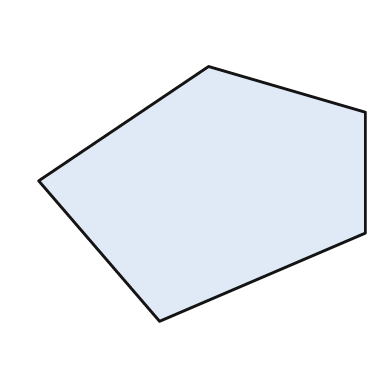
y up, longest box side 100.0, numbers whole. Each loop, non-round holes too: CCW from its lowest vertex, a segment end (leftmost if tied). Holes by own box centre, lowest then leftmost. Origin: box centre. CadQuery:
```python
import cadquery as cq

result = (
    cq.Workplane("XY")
    .moveTo(-13.0, -39.0)
    .lineTo(50.0, -12.0)
    .lineTo(50.0, 25.0)
    .lineTo(2.0, 39.0)
    .lineTo(-50.0, 4.0)
    .close()
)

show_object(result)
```